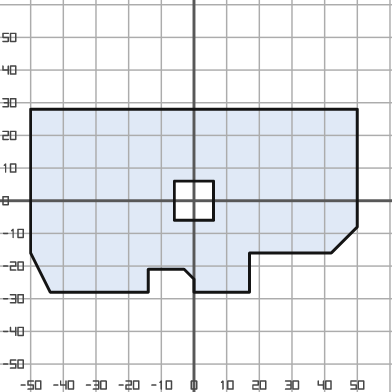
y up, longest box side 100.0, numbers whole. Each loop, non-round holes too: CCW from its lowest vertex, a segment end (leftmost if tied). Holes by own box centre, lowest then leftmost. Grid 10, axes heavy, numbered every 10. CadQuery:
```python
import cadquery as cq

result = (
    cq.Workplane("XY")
    .moveTo(-44.0, -28.0)
    .lineTo(-14.0, -28.0)
    .lineTo(-14.0, -21.0)
    .lineTo(-3.0, -21.0)
    .lineTo(0.0, -24.0)
    .lineTo(0.0, -28.0)
    .lineTo(17.0, -28.0)
    .lineTo(17.0, -16.0)
    .lineTo(42.0, -16.0)
    .lineTo(50.0, -8.0)
    .lineTo(50.0, 28.0)
    .lineTo(-50.0, 28.0)
    .lineTo(-50.0, -16.0)
    .close()
    .moveTo(-6.0, -6.0)
    .lineTo(6.0, -6.0)
    .lineTo(6.0, 6.0)
    .lineTo(-6.0, 6.0)
    .close()
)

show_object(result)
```